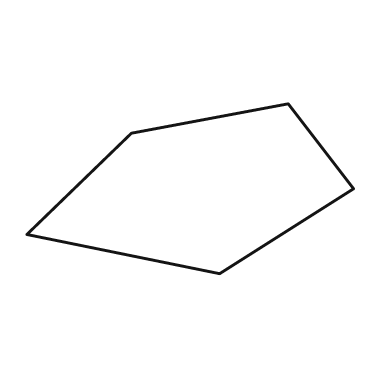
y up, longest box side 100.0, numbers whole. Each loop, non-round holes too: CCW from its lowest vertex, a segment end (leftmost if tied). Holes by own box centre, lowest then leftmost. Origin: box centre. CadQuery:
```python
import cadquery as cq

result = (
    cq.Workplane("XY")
    .moveTo(9.0, -26.0)
    .lineTo(50.0, 0.0)
    .lineTo(30.0, 26.0)
    .lineTo(-18.0, 17.0)
    .lineTo(-50.0, -14.0)
    .close()
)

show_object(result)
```